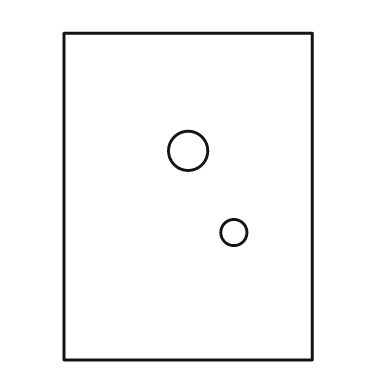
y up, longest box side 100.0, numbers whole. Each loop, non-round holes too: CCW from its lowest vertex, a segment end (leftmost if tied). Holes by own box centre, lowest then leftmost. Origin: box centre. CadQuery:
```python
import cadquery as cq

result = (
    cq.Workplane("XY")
    .moveTo(-38.0, -50.0)
    .lineTo(38.0, -50.0)
    .lineTo(38.0, 50.0)
    .lineTo(-38.0, 50.0)
    .close()
    .moveTo(14.0, -11.0)
    .circle(4.0)
    .moveTo(0.0, 14.0)
    .circle(6.0)
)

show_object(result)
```